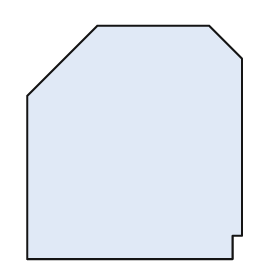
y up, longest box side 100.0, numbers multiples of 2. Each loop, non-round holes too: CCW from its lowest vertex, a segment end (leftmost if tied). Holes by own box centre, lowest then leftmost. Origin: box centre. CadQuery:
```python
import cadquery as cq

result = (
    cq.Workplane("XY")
    .moveTo(-46.0, -50.0)
    .lineTo(42.0, -50.0)
    .lineTo(42.0, -40.0)
    .lineTo(46.0, -40.0)
    .lineTo(46.0, 36.0)
    .lineTo(32.0, 50.0)
    .lineTo(-16.0, 50.0)
    .lineTo(-46.0, 20.0)
    .close()
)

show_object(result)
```